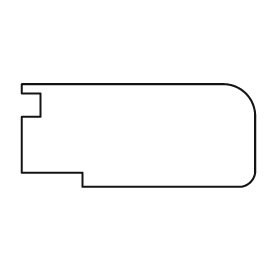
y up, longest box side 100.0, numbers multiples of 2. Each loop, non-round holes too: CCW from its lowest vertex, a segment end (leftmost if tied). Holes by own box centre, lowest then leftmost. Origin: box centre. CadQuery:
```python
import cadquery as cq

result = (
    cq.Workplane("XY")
    .moveTo(-24.0, -22.0)
    .lineTo(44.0, -22.0)
    .threePointArc((48.0, -20.0), (50.0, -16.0))
    .lineTo(50.0, 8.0)
    .threePointArc((46.0, 18.0), (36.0, 22.0))
    .lineTo(-50.0, 22.0)
    .lineTo(-50.0, 18.0)
    .lineTo(-42.0, 18.0)
    .lineTo(-42.0, 8.0)
    .lineTo(-50.0, 8.0)
    .lineTo(-50.0, -16.0)
    .lineTo(-24.0, -16.0)
    .close()
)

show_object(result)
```